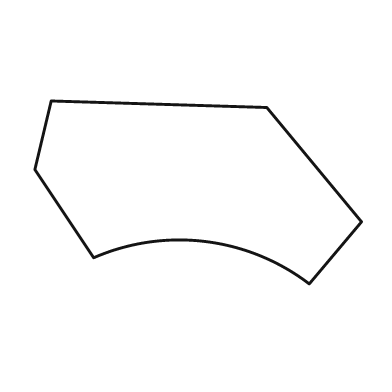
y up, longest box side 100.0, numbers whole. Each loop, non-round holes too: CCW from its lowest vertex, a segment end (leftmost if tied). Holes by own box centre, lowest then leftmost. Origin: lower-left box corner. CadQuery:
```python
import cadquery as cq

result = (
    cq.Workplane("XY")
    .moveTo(84.0, 0.0)
    .lineTo(100.0, 19.0)
    .lineTo(71.0, 54.0)
    .lineTo(5.0, 56.0)
    .lineTo(0.0, 35.0)
    .lineTo(18.0, 8.0)
    .threePointArc((52.0, 13.0), (84.0, 0.0))
    .close()
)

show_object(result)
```